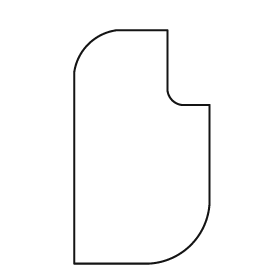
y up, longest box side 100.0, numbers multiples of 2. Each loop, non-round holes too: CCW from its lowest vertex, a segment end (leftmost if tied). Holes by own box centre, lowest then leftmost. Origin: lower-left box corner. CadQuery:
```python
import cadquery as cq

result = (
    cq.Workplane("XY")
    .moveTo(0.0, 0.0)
    .lineTo(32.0, 0.0)
    .threePointArc((50.0, 8.0), (58.0, 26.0))
    .lineTo(58.0, 68.0)
    .lineTo(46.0, 68.0)
    .threePointArc((42.0, 70.0), (40.0, 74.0))
    .lineTo(40.0, 100.0)
    .lineTo(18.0, 100.0)
    .threePointArc((6.0, 94.0), (0.0, 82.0))
    .close()
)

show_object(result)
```